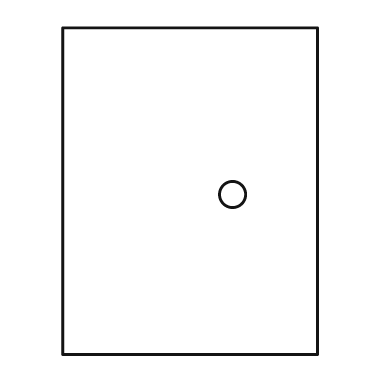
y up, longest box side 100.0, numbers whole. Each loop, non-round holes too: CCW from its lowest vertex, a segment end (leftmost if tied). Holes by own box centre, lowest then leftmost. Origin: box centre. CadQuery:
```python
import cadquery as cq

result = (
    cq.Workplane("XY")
    .moveTo(-39.0, -50.0)
    .lineTo(39.0, -50.0)
    .lineTo(39.0, 50.0)
    .lineTo(-39.0, 50.0)
    .close()
    .moveTo(13.0, -1.0)
    .circle(4.0)
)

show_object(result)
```